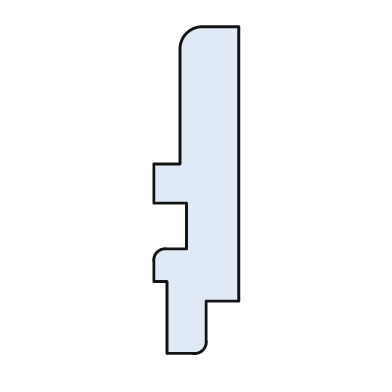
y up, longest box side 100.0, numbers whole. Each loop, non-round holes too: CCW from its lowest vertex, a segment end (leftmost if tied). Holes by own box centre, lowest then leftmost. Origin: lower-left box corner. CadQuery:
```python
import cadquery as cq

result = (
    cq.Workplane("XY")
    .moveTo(4.0, 0.0)
    .lineTo(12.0, 0.0)
    .threePointArc((15.0, 1.0), (16.0, 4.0))
    .lineTo(16.0, 16.0)
    .lineTo(26.0, 16.0)
    .lineTo(26.0, 100.0)
    .lineTo(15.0, 100.0)
    .threePointArc((10.0, 98.0), (8.0, 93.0))
    .lineTo(8.0, 58.0)
    .lineTo(0.0, 58.0)
    .lineTo(0.0, 46.0)
    .lineTo(10.0, 46.0)
    .lineTo(10.0, 32.0)
    .lineTo(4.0, 32.0)
    .threePointArc((1.0, 31.0), (0.0, 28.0))
    .lineTo(0.0, 22.0)
    .lineTo(4.0, 22.0)
    .close()
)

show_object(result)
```